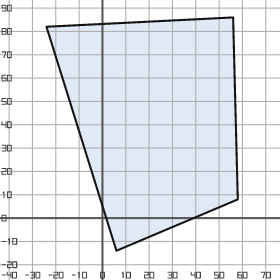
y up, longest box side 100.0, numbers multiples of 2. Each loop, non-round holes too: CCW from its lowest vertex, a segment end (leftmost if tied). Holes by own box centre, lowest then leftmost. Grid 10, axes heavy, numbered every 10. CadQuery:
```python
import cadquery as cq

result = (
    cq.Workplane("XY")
    .moveTo(6.0, -14.0)
    .lineTo(58.0, 8.0)
    .lineTo(56.0, 86.0)
    .lineTo(-24.0, 82.0)
    .close()
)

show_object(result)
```